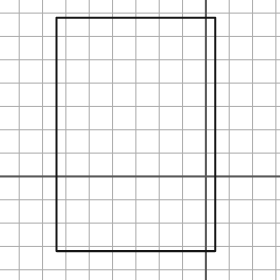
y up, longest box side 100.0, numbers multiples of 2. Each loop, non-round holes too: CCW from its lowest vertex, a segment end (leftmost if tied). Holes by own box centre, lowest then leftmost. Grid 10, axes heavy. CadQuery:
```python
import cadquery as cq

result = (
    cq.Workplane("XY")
    .moveTo(-64.0, -32.0)
    .lineTo(4.0, -32.0)
    .lineTo(4.0, 68.0)
    .lineTo(-64.0, 68.0)
    .close()
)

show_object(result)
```